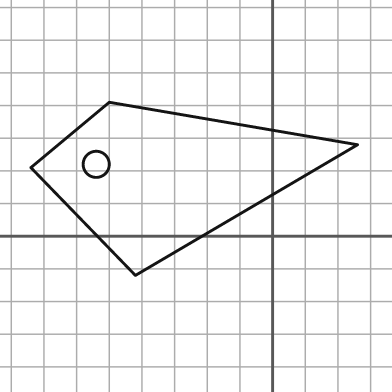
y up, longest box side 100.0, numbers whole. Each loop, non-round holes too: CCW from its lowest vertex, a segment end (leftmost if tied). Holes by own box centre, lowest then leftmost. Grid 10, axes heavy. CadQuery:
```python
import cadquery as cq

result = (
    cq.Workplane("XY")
    .moveTo(-42.0, -12.0)
    .lineTo(26.0, 28.0)
    .lineTo(-50.0, 41.0)
    .lineTo(-74.0, 21.0)
    .close()
    .moveTo(-54.0, 22.0)
    .circle(4.0)
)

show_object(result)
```